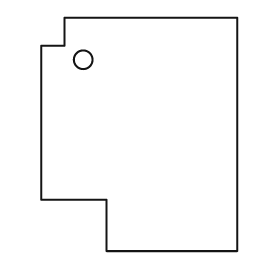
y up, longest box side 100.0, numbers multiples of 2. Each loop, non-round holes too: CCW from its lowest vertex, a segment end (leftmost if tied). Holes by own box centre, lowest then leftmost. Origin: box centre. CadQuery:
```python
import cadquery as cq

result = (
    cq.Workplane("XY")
    .moveTo(-14.0, -50.0)
    .lineTo(42.0, -50.0)
    .lineTo(42.0, 50.0)
    .lineTo(-32.0, 50.0)
    .lineTo(-32.0, 38.0)
    .lineTo(-42.0, 38.0)
    .lineTo(-42.0, -28.0)
    .lineTo(-14.0, -28.0)
    .close()
    .moveTo(-24.0, 32.0)
    .circle(4.0)
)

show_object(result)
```